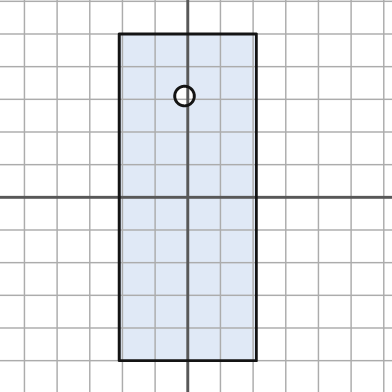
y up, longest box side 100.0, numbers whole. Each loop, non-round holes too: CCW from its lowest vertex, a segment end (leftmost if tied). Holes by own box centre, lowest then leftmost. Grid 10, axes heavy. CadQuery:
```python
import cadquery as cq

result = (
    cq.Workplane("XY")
    .moveTo(-21.0, -50.0)
    .lineTo(21.0, -50.0)
    .lineTo(21.0, 50.0)
    .lineTo(-21.0, 50.0)
    .close()
    .moveTo(-1.0, 31.0)
    .circle(3.0)
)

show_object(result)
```